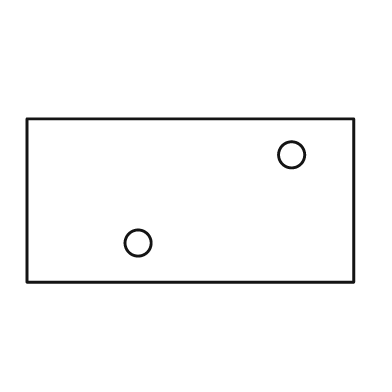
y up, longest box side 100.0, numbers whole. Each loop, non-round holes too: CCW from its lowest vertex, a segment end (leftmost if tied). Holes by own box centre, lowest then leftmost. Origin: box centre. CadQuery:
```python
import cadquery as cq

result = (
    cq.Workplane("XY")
    .moveTo(-50.0, -25.0)
    .lineTo(50.0, -25.0)
    .lineTo(50.0, 25.0)
    .lineTo(-50.0, 25.0)
    .close()
    .moveTo(-16.0, -13.0)
    .circle(4.0)
    .moveTo(31.0, 14.0)
    .circle(4.0)
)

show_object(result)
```